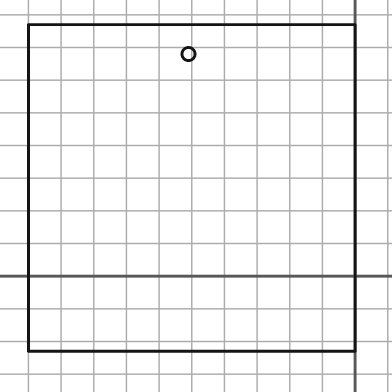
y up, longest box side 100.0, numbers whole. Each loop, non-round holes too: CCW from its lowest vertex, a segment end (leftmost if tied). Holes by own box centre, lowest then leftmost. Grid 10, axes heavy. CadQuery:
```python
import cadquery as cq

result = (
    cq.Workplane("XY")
    .moveTo(-100.0, -23.0)
    .lineTo(0.0, -23.0)
    .lineTo(0.0, 77.0)
    .lineTo(-100.0, 77.0)
    .close()
    .moveTo(-51.0, 68.0)
    .circle(2.0)
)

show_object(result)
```